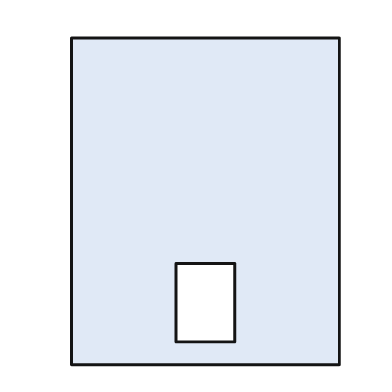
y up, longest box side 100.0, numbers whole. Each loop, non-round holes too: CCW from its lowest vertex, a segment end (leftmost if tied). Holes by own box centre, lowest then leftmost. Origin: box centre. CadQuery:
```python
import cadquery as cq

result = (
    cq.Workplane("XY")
    .moveTo(-41.0, -50.0)
    .lineTo(41.0, -50.0)
    .lineTo(41.0, 50.0)
    .lineTo(-41.0, 50.0)
    .close()
    .moveTo(-9.0, -43.0)
    .lineTo(9.0, -43.0)
    .lineTo(9.0, -19.0)
    .lineTo(-9.0, -19.0)
    .close()
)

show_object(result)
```